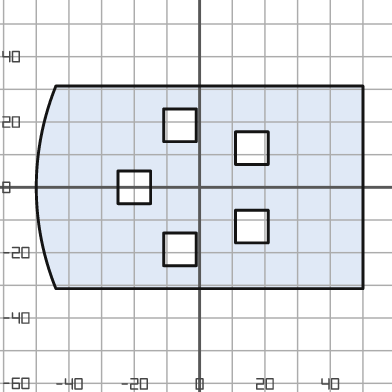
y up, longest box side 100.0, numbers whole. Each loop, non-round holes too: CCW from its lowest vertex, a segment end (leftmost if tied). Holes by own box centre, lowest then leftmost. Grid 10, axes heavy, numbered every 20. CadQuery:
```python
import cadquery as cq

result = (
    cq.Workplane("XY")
    .moveTo(-44.0, -31.0)
    .lineTo(50.0, -31.0)
    .lineTo(50.0, 31.0)
    .lineTo(-44.0, 31.0)
    .threePointArc((-50.0, 0.0), (-44.0, -31.0))
    .close()
    .moveTo(-11.0, -24.0)
    .lineTo(-1.0, -24.0)
    .lineTo(-1.0, -14.0)
    .lineTo(-11.0, -14.0)
    .close()
    .moveTo(11.0, -17.0)
    .lineTo(21.0, -17.0)
    .lineTo(21.0, -7.0)
    .lineTo(11.0, -7.0)
    .close()
    .moveTo(-25.0, -5.0)
    .lineTo(-15.0, -5.0)
    .lineTo(-15.0, 5.0)
    .lineTo(-25.0, 5.0)
    .close()
    .moveTo(11.0, 7.0)
    .lineTo(21.0, 7.0)
    .lineTo(21.0, 17.0)
    .lineTo(11.0, 17.0)
    .close()
    .moveTo(-11.0, 14.0)
    .lineTo(-1.0, 14.0)
    .lineTo(-1.0, 24.0)
    .lineTo(-11.0, 24.0)
    .close()
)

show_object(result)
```